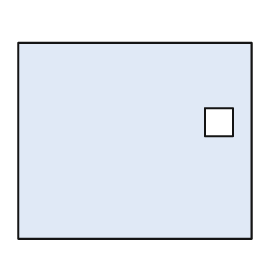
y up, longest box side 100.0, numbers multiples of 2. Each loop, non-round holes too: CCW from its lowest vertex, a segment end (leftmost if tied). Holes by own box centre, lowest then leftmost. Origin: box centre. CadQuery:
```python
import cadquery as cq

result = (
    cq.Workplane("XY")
    .moveTo(-50.0, -42.0)
    .lineTo(50.0, -42.0)
    .lineTo(50.0, 42.0)
    .lineTo(-50.0, 42.0)
    .close()
    .moveTo(30.0, 2.0)
    .lineTo(42.0, 2.0)
    .lineTo(42.0, 14.0)
    .lineTo(30.0, 14.0)
    .close()
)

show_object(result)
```